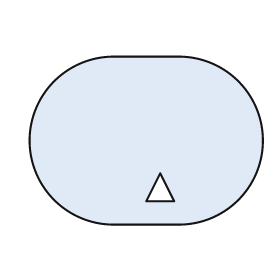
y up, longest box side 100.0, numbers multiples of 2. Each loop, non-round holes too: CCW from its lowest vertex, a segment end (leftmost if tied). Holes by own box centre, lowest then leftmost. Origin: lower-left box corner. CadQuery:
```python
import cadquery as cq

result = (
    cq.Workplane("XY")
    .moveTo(36.0, 0.0)
    .lineTo(64.0, 0.0)
    .threePointArc((100.0, 36.0), (64.0, 72.0))
    .lineTo(36.0, 72.0)
    .threePointArc((0.0, 36.0), (36.0, 0.0))
    .close()
    .moveTo(50.0, 10.0)
    .lineTo(62.0, 10.0)
    .lineTo(56.0, 22.0)
    .close()
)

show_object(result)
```